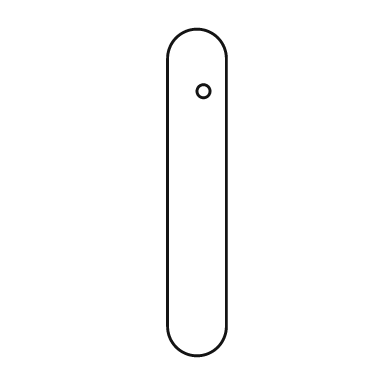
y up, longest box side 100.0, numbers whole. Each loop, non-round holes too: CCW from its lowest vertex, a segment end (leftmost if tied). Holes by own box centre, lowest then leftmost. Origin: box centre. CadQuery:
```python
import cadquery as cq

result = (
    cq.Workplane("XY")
    .moveTo(-9.0, -41.0)
    .threePointArc((0.0, -50.0), (9.0, -41.0))
    .lineTo(9.0, 41.0)
    .threePointArc((0.0, 50.0), (-9.0, 41.0))
    .close()
    .moveTo(2.0, 31.0)
    .circle(2.0)
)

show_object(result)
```